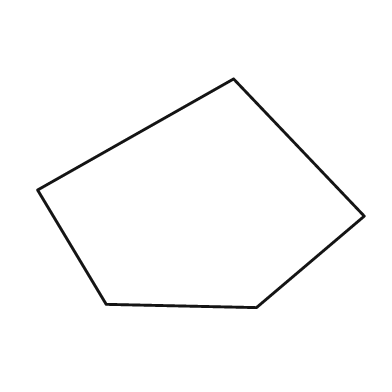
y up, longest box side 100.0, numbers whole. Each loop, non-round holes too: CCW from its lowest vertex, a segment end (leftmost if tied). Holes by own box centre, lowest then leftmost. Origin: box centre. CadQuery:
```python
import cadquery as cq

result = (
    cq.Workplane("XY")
    .moveTo(17.0, -35.0)
    .lineTo(50.0, -7.0)
    .lineTo(10.0, 35.0)
    .lineTo(-50.0, 1.0)
    .lineTo(-29.0, -34.0)
    .close()
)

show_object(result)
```